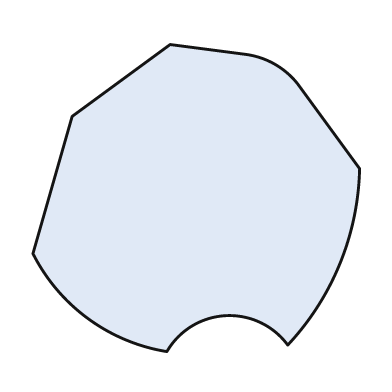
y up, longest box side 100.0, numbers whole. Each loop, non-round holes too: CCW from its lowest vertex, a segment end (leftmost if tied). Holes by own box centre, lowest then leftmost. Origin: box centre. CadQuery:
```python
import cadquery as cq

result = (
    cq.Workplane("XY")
    .moveTo(-9.0, -47.0)
    .threePointArc((9.0, -36.0), (28.0, -45.0))
    .threePointArc((44.0, -20.0), (50.0, 9.0))
    .lineTo(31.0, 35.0)
    .threePointArc((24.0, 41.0), (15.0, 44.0))
    .lineTo(-8.0, 47.0)
    .lineTo(-38.0, 25.0)
    .lineTo(-50.0, -17.0)
    .threePointArc((-33.0, -37.0), (-9.0, -47.0))
    .close()
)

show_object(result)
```